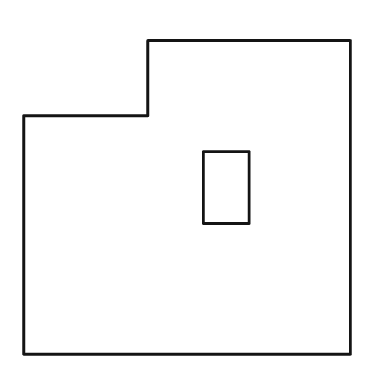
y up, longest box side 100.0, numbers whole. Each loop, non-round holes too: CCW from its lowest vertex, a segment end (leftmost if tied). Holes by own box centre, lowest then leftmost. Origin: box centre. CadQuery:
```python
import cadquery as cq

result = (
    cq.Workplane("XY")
    .moveTo(-50.0, -48.0)
    .lineTo(50.0, -48.0)
    .lineTo(50.0, 48.0)
    .lineTo(-12.0, 48.0)
    .lineTo(-12.0, 25.0)
    .lineTo(-50.0, 25.0)
    .close()
    .moveTo(5.0, -8.0)
    .lineTo(19.0, -8.0)
    .lineTo(19.0, 14.0)
    .lineTo(5.0, 14.0)
    .close()
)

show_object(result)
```